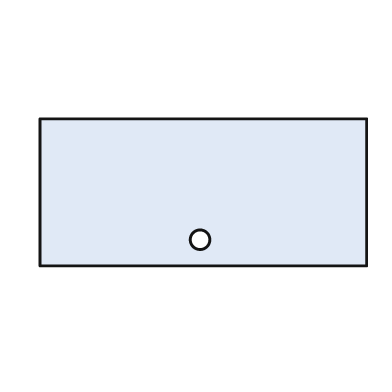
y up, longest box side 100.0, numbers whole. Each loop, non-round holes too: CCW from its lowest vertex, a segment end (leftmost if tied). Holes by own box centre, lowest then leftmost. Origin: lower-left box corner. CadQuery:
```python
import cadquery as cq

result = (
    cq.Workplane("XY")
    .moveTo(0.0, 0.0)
    .lineTo(100.0, 0.0)
    .lineTo(100.0, 45.0)
    .lineTo(0.0, 45.0)
    .close()
    .moveTo(49.0, 8.0)
    .circle(3.0)
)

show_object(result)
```